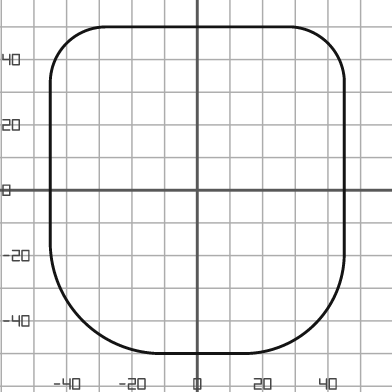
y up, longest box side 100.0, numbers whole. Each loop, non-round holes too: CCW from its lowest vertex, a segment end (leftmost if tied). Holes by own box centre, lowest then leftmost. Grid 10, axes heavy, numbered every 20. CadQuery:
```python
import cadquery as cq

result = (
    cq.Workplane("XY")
    .moveTo(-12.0, -50.0)
    .lineTo(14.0, -50.0)
    .threePointArc((36.0, -41.0), (45.0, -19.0))
    .lineTo(45.0, 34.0)
    .threePointArc((40.0, 45.0), (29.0, 50.0))
    .lineTo(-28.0, 50.0)
    .threePointArc((-40.0, 45.0), (-45.0, 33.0))
    .lineTo(-45.0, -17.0)
    .threePointArc((-35.0, -40.0), (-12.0, -50.0))
    .close()
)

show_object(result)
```